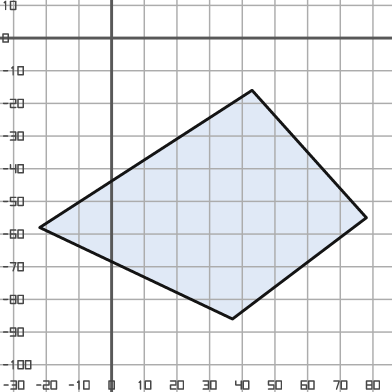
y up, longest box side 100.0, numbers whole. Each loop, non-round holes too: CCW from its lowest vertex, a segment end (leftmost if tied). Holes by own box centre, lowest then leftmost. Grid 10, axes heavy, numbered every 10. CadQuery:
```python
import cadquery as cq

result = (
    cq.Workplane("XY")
    .moveTo(37.0, -86.0)
    .lineTo(78.0, -55.0)
    .lineTo(43.0, -16.0)
    .lineTo(-22.0, -58.0)
    .close()
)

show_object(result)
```